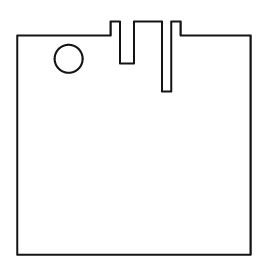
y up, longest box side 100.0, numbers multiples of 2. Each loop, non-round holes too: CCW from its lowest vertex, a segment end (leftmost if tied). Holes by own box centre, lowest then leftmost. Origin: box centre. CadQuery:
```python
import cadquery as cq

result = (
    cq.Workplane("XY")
    .moveTo(-50.0, -50.0)
    .lineTo(50.0, -50.0)
    .lineTo(50.0, 44.0)
    .lineTo(20.0, 44.0)
    .lineTo(20.0, 50.0)
    .lineTo(16.0, 50.0)
    .lineTo(16.0, 20.0)
    .lineTo(12.0, 20.0)
    .lineTo(12.0, 50.0)
    .lineTo(0.0, 50.0)
    .lineTo(0.0, 32.0)
    .lineTo(-6.0, 32.0)
    .lineTo(-6.0, 50.0)
    .lineTo(-10.0, 50.0)
    .lineTo(-10.0, 44.0)
    .lineTo(-50.0, 44.0)
    .close()
    .moveTo(-28.0, 34.0)
    .circle(6.0)
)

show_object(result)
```